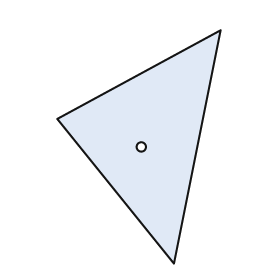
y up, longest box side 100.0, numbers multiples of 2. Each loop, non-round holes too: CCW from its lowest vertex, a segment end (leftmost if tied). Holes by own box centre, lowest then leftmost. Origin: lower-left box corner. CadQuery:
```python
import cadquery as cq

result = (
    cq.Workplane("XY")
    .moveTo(50.0, 0.0)
    .lineTo(70.0, 100.0)
    .lineTo(0.0, 62.0)
    .close()
    .moveTo(36.0, 50.0)
    .circle(2.0)
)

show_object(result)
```